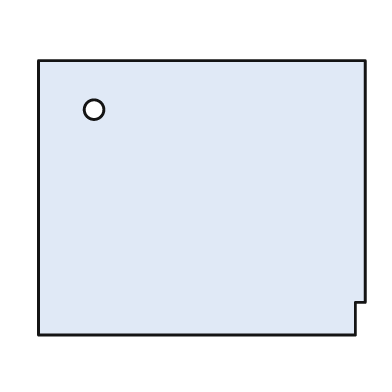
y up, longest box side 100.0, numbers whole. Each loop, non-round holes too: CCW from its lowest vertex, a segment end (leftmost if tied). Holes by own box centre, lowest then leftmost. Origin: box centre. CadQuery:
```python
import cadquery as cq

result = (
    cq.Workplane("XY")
    .moveTo(-50.0, -42.0)
    .lineTo(47.0, -42.0)
    .lineTo(47.0, -32.0)
    .lineTo(50.0, -32.0)
    .lineTo(50.0, 42.0)
    .lineTo(-50.0, 42.0)
    .close()
    .moveTo(-33.0, 27.0)
    .circle(3.0)
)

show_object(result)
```